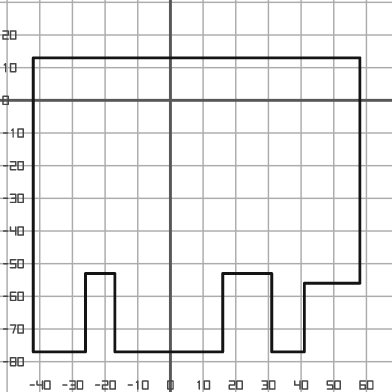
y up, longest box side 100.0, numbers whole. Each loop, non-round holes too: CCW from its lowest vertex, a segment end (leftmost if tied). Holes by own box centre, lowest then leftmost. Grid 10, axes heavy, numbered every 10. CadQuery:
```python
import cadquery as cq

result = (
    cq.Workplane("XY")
    .moveTo(-42.0, -77.0)
    .lineTo(-26.0, -77.0)
    .lineTo(-26.0, -53.0)
    .lineTo(-17.0, -53.0)
    .lineTo(-17.0, -77.0)
    .lineTo(16.0, -77.0)
    .lineTo(16.0, -53.0)
    .lineTo(31.0, -53.0)
    .lineTo(31.0, -77.0)
    .lineTo(41.0, -77.0)
    .lineTo(41.0, -56.0)
    .lineTo(58.0, -56.0)
    .lineTo(58.0, 13.0)
    .lineTo(-42.0, 13.0)
    .close()
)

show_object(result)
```